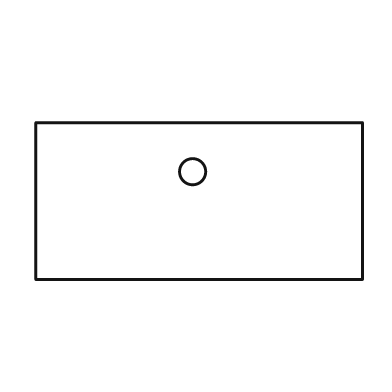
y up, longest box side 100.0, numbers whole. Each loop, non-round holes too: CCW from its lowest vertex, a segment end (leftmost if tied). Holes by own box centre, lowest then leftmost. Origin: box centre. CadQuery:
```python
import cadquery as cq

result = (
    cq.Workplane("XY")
    .moveTo(-50.0, -24.0)
    .lineTo(50.0, -24.0)
    .lineTo(50.0, 24.0)
    .lineTo(-50.0, 24.0)
    .close()
    .moveTo(-2.0, 9.0)
    .circle(4.0)
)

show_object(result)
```